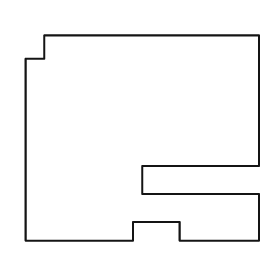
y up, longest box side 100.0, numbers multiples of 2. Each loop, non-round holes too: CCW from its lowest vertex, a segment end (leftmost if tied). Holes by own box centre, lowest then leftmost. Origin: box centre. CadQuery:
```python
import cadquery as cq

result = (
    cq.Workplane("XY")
    .moveTo(-50.0, -44.0)
    .lineTo(-4.0, -44.0)
    .lineTo(-4.0, -36.0)
    .lineTo(16.0, -36.0)
    .lineTo(16.0, -44.0)
    .lineTo(50.0, -44.0)
    .lineTo(50.0, -24.0)
    .lineTo(0.0, -24.0)
    .lineTo(0.0, -12.0)
    .lineTo(50.0, -12.0)
    .lineTo(50.0, 44.0)
    .lineTo(-42.0, 44.0)
    .lineTo(-42.0, 34.0)
    .lineTo(-50.0, 34.0)
    .close()
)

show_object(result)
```